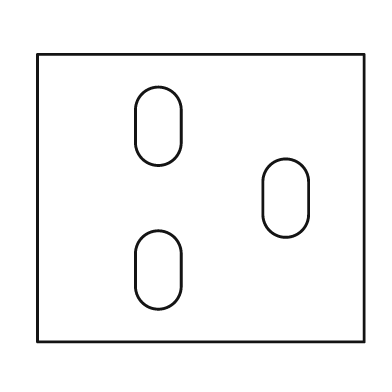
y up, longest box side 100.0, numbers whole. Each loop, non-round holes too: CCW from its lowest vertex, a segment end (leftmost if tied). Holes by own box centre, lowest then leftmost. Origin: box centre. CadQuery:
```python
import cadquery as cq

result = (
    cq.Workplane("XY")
    .moveTo(-50.0, -44.0)
    .lineTo(50.0, -44.0)
    .lineTo(50.0, 44.0)
    .lineTo(-50.0, 44.0)
    .close()
    .moveTo(-20.0, -27.0)
    .threePointArc((-13.0, -34.0), (-6.0, -27.0))
    .lineTo(-6.0, -17.0)
    .threePointArc((-13.0, -10.0), (-20.0, -17.0))
    .close()
    .moveTo(19.0, -5.0)
    .threePointArc((26.0, -12.0), (33.0, -5.0))
    .lineTo(33.0, 5.0)
    .threePointArc((26.0, 12.0), (19.0, 5.0))
    .close()
    .moveTo(-20.0, 17.0)
    .threePointArc((-13.0, 10.0), (-6.0, 17.0))
    .lineTo(-6.0, 27.0)
    .threePointArc((-13.0, 34.0), (-20.0, 27.0))
    .close()
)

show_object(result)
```